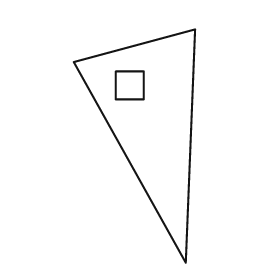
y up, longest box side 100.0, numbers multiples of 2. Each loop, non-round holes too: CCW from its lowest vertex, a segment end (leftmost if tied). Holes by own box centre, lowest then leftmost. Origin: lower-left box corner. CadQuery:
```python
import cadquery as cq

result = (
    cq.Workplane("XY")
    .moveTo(48.0, 0.0)
    .lineTo(52.0, 100.0)
    .lineTo(0.0, 86.0)
    .close()
    .moveTo(18.0, 70.0)
    .lineTo(30.0, 70.0)
    .lineTo(30.0, 82.0)
    .lineTo(18.0, 82.0)
    .close()
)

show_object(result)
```